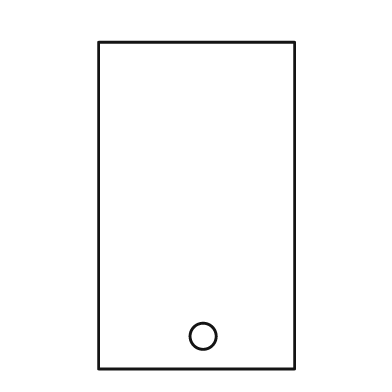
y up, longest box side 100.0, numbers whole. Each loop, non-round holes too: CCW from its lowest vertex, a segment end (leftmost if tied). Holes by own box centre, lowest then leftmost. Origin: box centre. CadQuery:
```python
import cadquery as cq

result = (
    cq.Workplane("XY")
    .moveTo(-30.0, -50.0)
    .lineTo(30.0, -50.0)
    .lineTo(30.0, 50.0)
    .lineTo(-30.0, 50.0)
    .close()
    .moveTo(2.0, -40.0)
    .circle(4.0)
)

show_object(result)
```